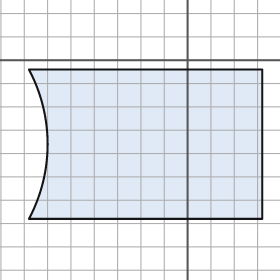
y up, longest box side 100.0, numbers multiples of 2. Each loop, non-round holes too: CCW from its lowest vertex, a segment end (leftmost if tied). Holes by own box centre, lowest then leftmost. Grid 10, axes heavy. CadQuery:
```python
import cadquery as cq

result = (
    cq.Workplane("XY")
    .moveTo(-68.0, -68.0)
    .lineTo(32.0, -68.0)
    .lineTo(32.0, -4.0)
    .lineTo(-68.0, -4.0)
    .threePointArc((-60.0, -36.0), (-68.0, -68.0))
    .close()
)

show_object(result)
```